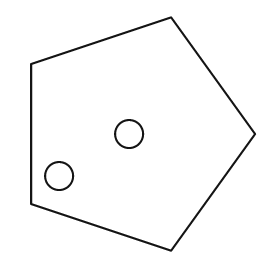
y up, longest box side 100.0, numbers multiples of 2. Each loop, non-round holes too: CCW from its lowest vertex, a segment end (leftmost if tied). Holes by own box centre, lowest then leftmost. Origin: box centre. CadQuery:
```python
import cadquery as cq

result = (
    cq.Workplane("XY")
    .moveTo(12.0, -50.0)
    .lineTo(48.0, 0.0)
    .lineTo(12.0, 50.0)
    .lineTo(-48.0, 30.0)
    .lineTo(-48.0, -30.0)
    .close()
    .moveTo(-36.0, -18.0)
    .circle(6.0)
    .moveTo(-6.0, 0.0)
    .circle(6.0)
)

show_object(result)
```